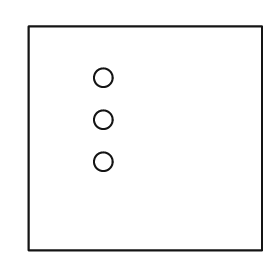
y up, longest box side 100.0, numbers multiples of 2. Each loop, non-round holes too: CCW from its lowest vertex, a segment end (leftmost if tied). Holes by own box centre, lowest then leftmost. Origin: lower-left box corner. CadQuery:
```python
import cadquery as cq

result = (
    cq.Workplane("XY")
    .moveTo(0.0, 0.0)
    .lineTo(100.0, 0.0)
    .lineTo(100.0, 96.0)
    .lineTo(0.0, 96.0)
    .close()
    .moveTo(32.0, 38.0)
    .circle(4.0)
    .moveTo(32.0, 56.0)
    .circle(4.0)
    .moveTo(32.0, 74.0)
    .circle(4.0)
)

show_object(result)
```